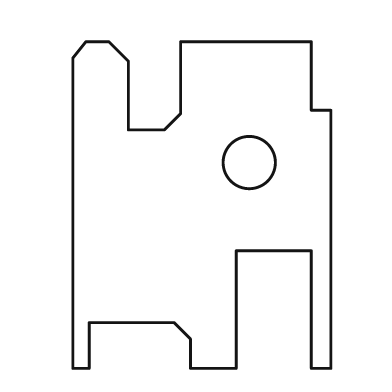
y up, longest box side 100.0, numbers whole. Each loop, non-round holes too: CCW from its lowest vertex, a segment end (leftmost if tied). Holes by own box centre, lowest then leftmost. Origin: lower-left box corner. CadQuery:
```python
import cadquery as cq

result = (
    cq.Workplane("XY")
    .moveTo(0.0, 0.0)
    .lineTo(5.0, 0.0)
    .lineTo(5.0, 14.0)
    .lineTo(31.0, 14.0)
    .lineTo(36.0, 9.0)
    .lineTo(36.0, 0.0)
    .lineTo(50.0, 0.0)
    .lineTo(50.0, 36.0)
    .lineTo(73.0, 36.0)
    .lineTo(73.0, 0.0)
    .lineTo(79.0, 0.0)
    .lineTo(79.0, 79.0)
    .lineTo(73.0, 79.0)
    .lineTo(73.0, 100.0)
    .lineTo(33.0, 100.0)
    .lineTo(33.0, 78.0)
    .lineTo(28.0, 73.0)
    .lineTo(17.0, 73.0)
    .lineTo(17.0, 94.0)
    .lineTo(11.0, 100.0)
    .lineTo(4.0, 100.0)
    .lineTo(0.0, 95.0)
    .close()
    .moveTo(54.0, 63.0)
    .circle(8.0)
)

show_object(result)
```